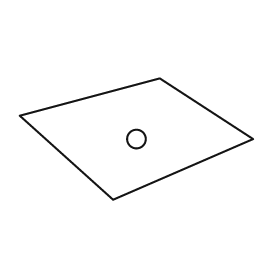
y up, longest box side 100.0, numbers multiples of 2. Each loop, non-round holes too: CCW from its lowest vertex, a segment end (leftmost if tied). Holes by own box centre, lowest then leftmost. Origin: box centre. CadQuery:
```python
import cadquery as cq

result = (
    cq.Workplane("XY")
    .moveTo(-10.0, -26.0)
    .lineTo(50.0, 0.0)
    .lineTo(10.0, 26.0)
    .lineTo(-50.0, 10.0)
    .close()
    .moveTo(0.0, 0.0)
    .circle(4.0)
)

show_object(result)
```